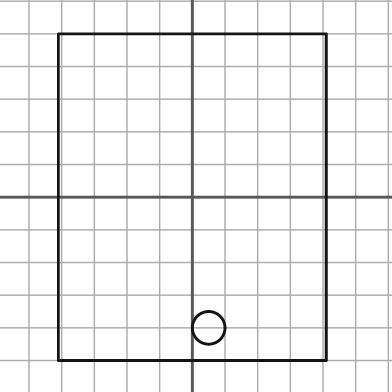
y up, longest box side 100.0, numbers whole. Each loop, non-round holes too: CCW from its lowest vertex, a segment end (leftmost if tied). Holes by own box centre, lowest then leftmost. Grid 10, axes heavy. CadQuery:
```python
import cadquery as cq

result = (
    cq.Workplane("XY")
    .moveTo(-41.0, -50.0)
    .lineTo(41.0, -50.0)
    .lineTo(41.0, 50.0)
    .lineTo(-41.0, 50.0)
    .close()
    .moveTo(5.0, -40.0)
    .circle(5.0)
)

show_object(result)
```